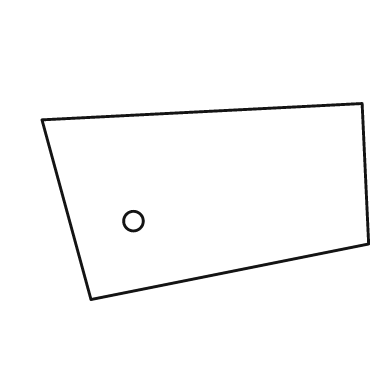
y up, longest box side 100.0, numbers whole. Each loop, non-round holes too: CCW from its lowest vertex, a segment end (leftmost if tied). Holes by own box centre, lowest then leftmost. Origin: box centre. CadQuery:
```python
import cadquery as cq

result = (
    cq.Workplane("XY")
    .moveTo(-35.0, -30.0)
    .lineTo(50.0, -13.0)
    .lineTo(48.0, 30.0)
    .lineTo(-50.0, 25.0)
    .close()
    .moveTo(-22.0, -6.0)
    .circle(3.0)
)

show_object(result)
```